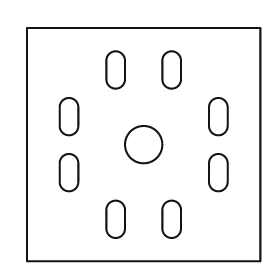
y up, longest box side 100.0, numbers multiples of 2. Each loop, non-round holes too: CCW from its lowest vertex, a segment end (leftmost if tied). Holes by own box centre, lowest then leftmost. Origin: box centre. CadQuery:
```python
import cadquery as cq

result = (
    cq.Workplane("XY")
    .moveTo(-50.0, -50.0)
    .lineTo(50.0, -50.0)
    .lineTo(50.0, 50.0)
    .lineTo(-50.0, 50.0)
    .close()
    .moveTo(-16.0, -36.0)
    .threePointArc((-12.0, -40.0), (-8.0, -36.0))
    .lineTo(-8.0, -28.0)
    .threePointArc((-12.0, -24.0), (-16.0, -28.0))
    .close()
    .moveTo(8.0, -36.0)
    .threePointArc((12.0, -40.0), (16.0, -36.0))
    .lineTo(16.0, -28.0)
    .threePointArc((12.0, -24.0), (8.0, -28.0))
    .close()
    .moveTo(-36.0, -16.0)
    .threePointArc((-32.0, -20.0), (-28.0, -16.0))
    .lineTo(-28.0, -8.0)
    .threePointArc((-32.0, -4.0), (-36.0, -8.0))
    .close()
    .moveTo(28.0, -16.0)
    .threePointArc((32.0, -20.0), (36.0, -16.0))
    .lineTo(36.0, -8.0)
    .threePointArc((32.0, -4.0), (28.0, -8.0))
    .close()
    .moveTo(0.0, 0.0)
    .circle(8.0)
    .moveTo(-36.0, 8.0)
    .threePointArc((-32.0, 4.0), (-28.0, 8.0))
    .lineTo(-28.0, 16.0)
    .threePointArc((-32.0, 20.0), (-36.0, 16.0))
    .close()
    .moveTo(28.0, 8.0)
    .threePointArc((32.0, 4.0), (36.0, 8.0))
    .lineTo(36.0, 16.0)
    .threePointArc((32.0, 20.0), (28.0, 16.0))
    .close()
    .moveTo(-16.0, 28.0)
    .threePointArc((-12.0, 24.0), (-8.0, 28.0))
    .lineTo(-8.0, 36.0)
    .threePointArc((-12.0, 40.0), (-16.0, 36.0))
    .close()
    .moveTo(8.0, 28.0)
    .threePointArc((12.0, 24.0), (16.0, 28.0))
    .lineTo(16.0, 36.0)
    .threePointArc((12.0, 40.0), (8.0, 36.0))
    .close()
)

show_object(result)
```